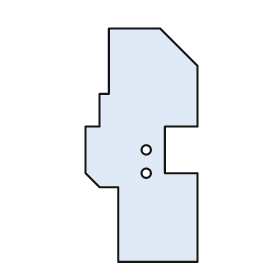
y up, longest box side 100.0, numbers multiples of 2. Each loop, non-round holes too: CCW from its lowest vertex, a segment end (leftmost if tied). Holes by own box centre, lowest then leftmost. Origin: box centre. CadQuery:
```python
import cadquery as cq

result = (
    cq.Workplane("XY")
    .moveTo(-10.0, -50.0)
    .lineTo(24.0, -50.0)
    .lineTo(24.0, -12.0)
    .lineTo(10.0, -12.0)
    .lineTo(10.0, 8.0)
    .lineTo(24.0, 8.0)
    .lineTo(24.0, 34.0)
    .lineTo(8.0, 50.0)
    .lineTo(-14.0, 50.0)
    .lineTo(-14.0, 22.0)
    .lineTo(-18.0, 22.0)
    .lineTo(-18.0, 8.0)
    .lineTo(-24.0, 8.0)
    .lineTo(-24.0, -12.0)
    .lineTo(-18.0, -18.0)
    .lineTo(-10.0, -18.0)
    .close()
    .moveTo(2.0, -12.0)
    .circle(2.0)
    .moveTo(2.0, -2.0)
    .circle(2.0)
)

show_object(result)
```